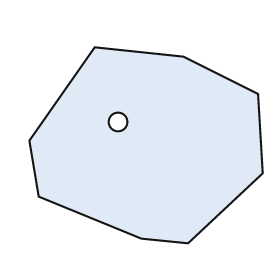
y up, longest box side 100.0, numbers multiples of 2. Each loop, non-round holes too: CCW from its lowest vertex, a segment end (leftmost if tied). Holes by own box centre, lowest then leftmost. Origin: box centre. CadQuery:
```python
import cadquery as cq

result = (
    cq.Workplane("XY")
    .moveTo(18.0, -42.0)
    .lineTo(50.0, -12.0)
    .lineTo(48.0, 22.0)
    .lineTo(16.0, 38.0)
    .lineTo(-22.0, 42.0)
    .lineTo(-50.0, 2.0)
    .lineTo(-46.0, -22.0)
    .lineTo(-2.0, -40.0)
    .close()
    .moveTo(-12.0, 10.0)
    .circle(4.0)
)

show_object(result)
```